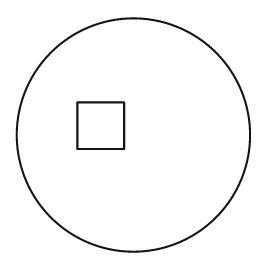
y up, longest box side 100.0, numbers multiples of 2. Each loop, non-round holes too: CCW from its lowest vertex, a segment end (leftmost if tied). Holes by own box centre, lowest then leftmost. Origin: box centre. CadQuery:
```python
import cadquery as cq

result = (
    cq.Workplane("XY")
    .moveTo(0.0, 0.0)
    .circle(50.0)
    .moveTo(-24.0, -6.0)
    .lineTo(-4.0, -6.0)
    .lineTo(-4.0, 14.0)
    .lineTo(-24.0, 14.0)
    .close()
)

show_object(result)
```